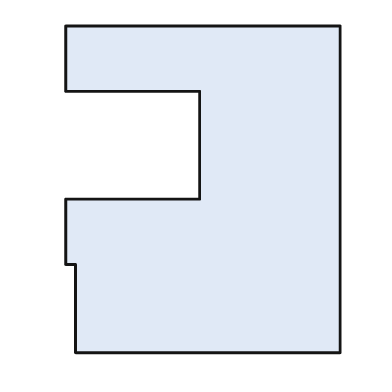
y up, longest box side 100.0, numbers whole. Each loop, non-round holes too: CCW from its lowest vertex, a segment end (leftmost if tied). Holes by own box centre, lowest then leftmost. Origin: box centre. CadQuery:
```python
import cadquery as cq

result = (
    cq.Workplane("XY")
    .moveTo(-39.0, -50.0)
    .lineTo(42.0, -50.0)
    .lineTo(42.0, 50.0)
    .lineTo(-42.0, 50.0)
    .lineTo(-42.0, 30.0)
    .lineTo(-1.0, 30.0)
    .lineTo(-1.0, -3.0)
    .lineTo(-42.0, -3.0)
    .lineTo(-42.0, -23.0)
    .lineTo(-39.0, -23.0)
    .close()
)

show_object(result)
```